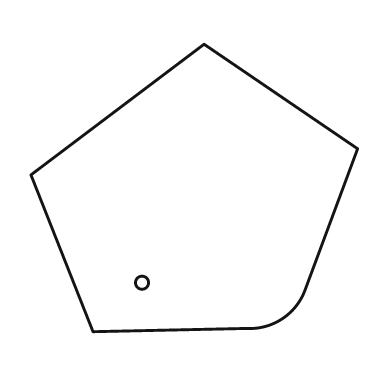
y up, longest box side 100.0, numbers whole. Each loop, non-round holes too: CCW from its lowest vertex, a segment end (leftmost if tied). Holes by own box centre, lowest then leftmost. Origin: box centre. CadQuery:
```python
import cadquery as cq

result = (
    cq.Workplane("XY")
    .moveTo(-31.0, -44.0)
    .lineTo(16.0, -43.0)
    .threePointArc((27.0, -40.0), (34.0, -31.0))
    .lineTo(50.0, 12.0)
    .lineTo(3.0, 44.0)
    .lineTo(-50.0, 4.0)
    .close()
    .moveTo(-16.0, -29.0)
    .circle(2.0)
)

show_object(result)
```